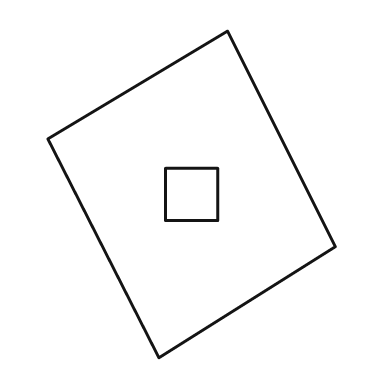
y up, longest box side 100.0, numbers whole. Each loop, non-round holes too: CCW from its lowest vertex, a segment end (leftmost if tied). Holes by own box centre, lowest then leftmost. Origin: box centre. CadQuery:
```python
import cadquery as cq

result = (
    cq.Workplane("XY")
    .moveTo(-10.0, -50.0)
    .lineTo(44.0, -16.0)
    .lineTo(11.0, 50.0)
    .lineTo(-44.0, 17.0)
    .close()
    .moveTo(-8.0, -8.0)
    .lineTo(8.0, -8.0)
    .lineTo(8.0, 8.0)
    .lineTo(-8.0, 8.0)
    .close()
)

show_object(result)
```